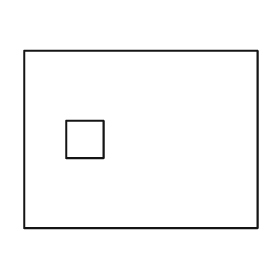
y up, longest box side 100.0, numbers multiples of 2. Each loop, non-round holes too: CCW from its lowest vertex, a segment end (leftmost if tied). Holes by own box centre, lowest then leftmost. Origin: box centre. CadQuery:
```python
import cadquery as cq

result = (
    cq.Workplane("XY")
    .moveTo(-50.0, -38.0)
    .lineTo(50.0, -38.0)
    .lineTo(50.0, 38.0)
    .lineTo(-50.0, 38.0)
    .close()
    .moveTo(-32.0, -8.0)
    .lineTo(-16.0, -8.0)
    .lineTo(-16.0, 8.0)
    .lineTo(-32.0, 8.0)
    .close()
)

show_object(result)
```